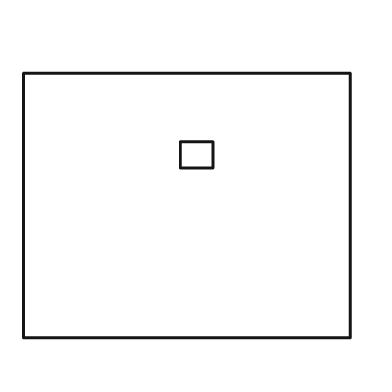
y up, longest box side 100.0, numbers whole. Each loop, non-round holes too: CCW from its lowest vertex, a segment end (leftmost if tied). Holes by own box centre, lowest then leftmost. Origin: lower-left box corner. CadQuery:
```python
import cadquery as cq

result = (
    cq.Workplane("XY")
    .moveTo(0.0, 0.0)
    .lineTo(100.0, 0.0)
    .lineTo(100.0, 81.0)
    .lineTo(0.0, 81.0)
    .close()
    .moveTo(48.0, 52.0)
    .lineTo(58.0, 52.0)
    .lineTo(58.0, 60.0)
    .lineTo(48.0, 60.0)
    .close()
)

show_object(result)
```